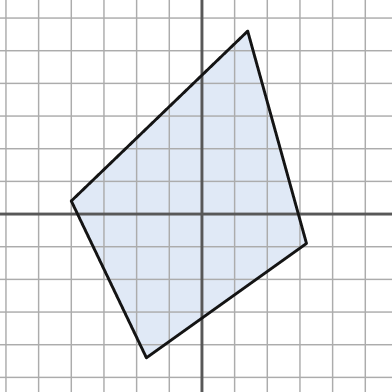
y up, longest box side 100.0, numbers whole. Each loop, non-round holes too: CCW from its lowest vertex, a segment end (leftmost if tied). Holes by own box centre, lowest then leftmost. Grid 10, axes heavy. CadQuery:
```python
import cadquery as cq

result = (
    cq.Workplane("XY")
    .moveTo(-17.0, -44.0)
    .lineTo(32.0, -9.0)
    .lineTo(14.0, 56.0)
    .lineTo(-40.0, 4.0)
    .close()
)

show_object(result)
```